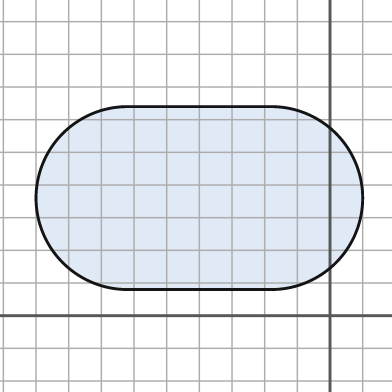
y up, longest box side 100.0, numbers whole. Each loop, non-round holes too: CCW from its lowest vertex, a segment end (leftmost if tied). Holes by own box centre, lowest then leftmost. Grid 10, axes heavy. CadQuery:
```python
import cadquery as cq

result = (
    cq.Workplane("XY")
    .moveTo(-62.0, 8.0)
    .lineTo(-18.0, 8.0)
    .threePointArc((10.0, 36.0), (-18.0, 64.0))
    .lineTo(-62.0, 64.0)
    .threePointArc((-90.0, 36.0), (-62.0, 8.0))
    .close()
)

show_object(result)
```